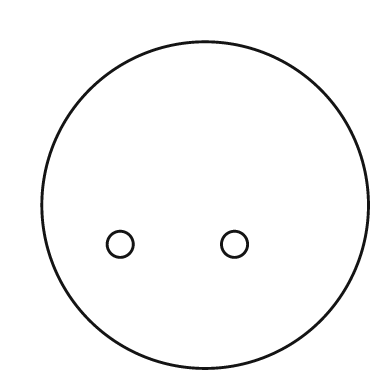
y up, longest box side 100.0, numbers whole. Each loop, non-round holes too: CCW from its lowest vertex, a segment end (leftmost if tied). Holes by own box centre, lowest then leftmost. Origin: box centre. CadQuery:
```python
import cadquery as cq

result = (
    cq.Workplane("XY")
    .moveTo(0.0, 0.0)
    .circle(50.0)
    .moveTo(-26.0, -12.0)
    .circle(4.0)
    .moveTo(9.0, -12.0)
    .circle(4.0)
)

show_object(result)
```